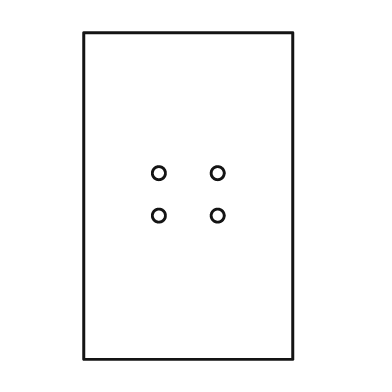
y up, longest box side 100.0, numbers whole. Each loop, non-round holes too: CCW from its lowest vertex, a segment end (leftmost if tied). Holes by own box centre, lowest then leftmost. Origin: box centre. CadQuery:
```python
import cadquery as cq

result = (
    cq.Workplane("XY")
    .moveTo(-32.0, -50.0)
    .lineTo(32.0, -50.0)
    .lineTo(32.0, 50.0)
    .lineTo(-32.0, 50.0)
    .close()
    .moveTo(-9.0, -6.0)
    .circle(2.0)
    .moveTo(9.0, -6.0)
    .circle(2.0)
    .moveTo(-9.0, 7.0)
    .circle(2.0)
    .moveTo(9.0, 7.0)
    .circle(2.0)
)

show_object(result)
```